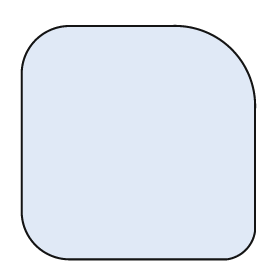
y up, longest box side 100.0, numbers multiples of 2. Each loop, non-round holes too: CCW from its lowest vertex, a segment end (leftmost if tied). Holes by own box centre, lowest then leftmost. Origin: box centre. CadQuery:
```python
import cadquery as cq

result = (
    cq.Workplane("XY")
    .moveTo(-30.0, -50.0)
    .lineTo(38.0, -50.0)
    .threePointArc((46.0, -46.0), (50.0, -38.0))
    .lineTo(50.0, 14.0)
    .threePointArc((40.0, 40.0), (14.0, 50.0))
    .lineTo(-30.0, 50.0)
    .threePointArc((-44.0, 44.0), (-50.0, 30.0))
    .lineTo(-50.0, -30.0)
    .threePointArc((-44.0, -44.0), (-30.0, -50.0))
    .close()
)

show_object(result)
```